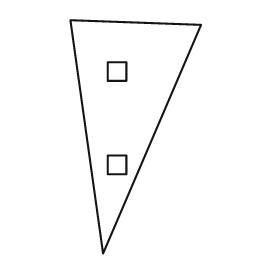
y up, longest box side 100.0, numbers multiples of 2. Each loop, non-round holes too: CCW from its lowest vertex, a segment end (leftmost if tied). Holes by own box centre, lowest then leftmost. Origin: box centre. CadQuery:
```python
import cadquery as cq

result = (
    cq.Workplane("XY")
    .moveTo(-14.0, -50.0)
    .lineTo(28.0, 48.0)
    .lineTo(-28.0, 50.0)
    .close()
    .moveTo(-12.0, -16.0)
    .lineTo(-4.0, -16.0)
    .lineTo(-4.0, -8.0)
    .lineTo(-12.0, -8.0)
    .close()
    .moveTo(-12.0, 24.0)
    .lineTo(-4.0, 24.0)
    .lineTo(-4.0, 32.0)
    .lineTo(-12.0, 32.0)
    .close()
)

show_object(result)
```